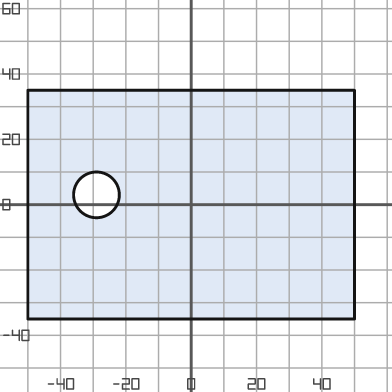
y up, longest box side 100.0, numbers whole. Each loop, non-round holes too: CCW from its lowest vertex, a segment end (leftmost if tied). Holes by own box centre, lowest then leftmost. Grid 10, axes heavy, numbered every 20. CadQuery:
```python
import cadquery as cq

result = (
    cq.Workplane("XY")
    .moveTo(-50.0, -35.0)
    .lineTo(50.0, -35.0)
    .lineTo(50.0, 35.0)
    .lineTo(-50.0, 35.0)
    .close()
    .moveTo(-29.0, 3.0)
    .circle(7.0)
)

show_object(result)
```